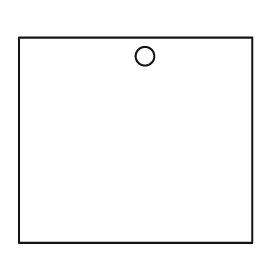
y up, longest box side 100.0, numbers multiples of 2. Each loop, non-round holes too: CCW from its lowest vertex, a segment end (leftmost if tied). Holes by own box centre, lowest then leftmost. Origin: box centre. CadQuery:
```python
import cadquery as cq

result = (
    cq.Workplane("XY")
    .moveTo(-50.0, -44.0)
    .lineTo(50.0, -44.0)
    .lineTo(50.0, 44.0)
    .lineTo(-50.0, 44.0)
    .close()
    .moveTo(4.0, 36.0)
    .circle(4.0)
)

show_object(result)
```